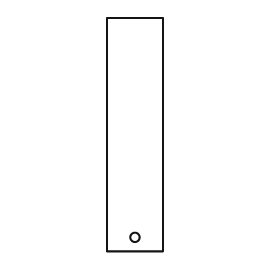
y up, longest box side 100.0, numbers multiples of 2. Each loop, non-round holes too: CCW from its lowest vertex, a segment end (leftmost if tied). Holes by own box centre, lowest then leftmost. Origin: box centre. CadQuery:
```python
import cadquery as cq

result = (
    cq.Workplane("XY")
    .moveTo(-12.0, -50.0)
    .lineTo(12.0, -50.0)
    .lineTo(12.0, 50.0)
    .lineTo(-12.0, 50.0)
    .close()
    .moveTo(0.0, -44.0)
    .circle(2.0)
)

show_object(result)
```